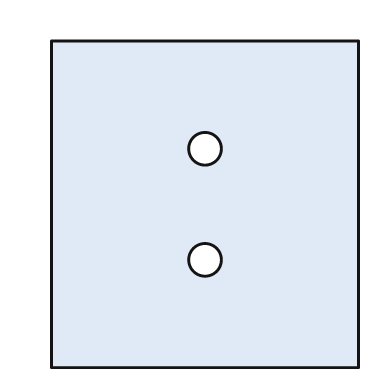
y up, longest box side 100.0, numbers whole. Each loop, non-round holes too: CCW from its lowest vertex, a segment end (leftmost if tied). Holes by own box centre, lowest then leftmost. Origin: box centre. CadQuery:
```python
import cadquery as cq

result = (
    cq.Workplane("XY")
    .moveTo(-47.0, -50.0)
    .lineTo(47.0, -50.0)
    .lineTo(47.0, 50.0)
    .lineTo(-47.0, 50.0)
    .close()
    .moveTo(0.0, -17.0)
    .circle(5.0)
    .moveTo(0.0, 17.0)
    .circle(5.0)
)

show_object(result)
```